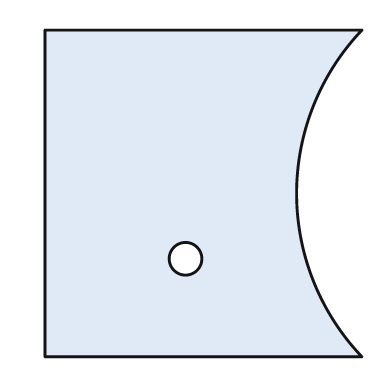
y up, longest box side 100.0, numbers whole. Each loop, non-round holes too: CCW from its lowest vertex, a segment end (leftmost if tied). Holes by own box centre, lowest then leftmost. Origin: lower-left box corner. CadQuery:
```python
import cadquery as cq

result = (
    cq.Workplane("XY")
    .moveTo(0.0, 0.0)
    .lineTo(97.0, 0.0)
    .threePointArc((77.0, 50.0), (97.0, 100.0))
    .lineTo(0.0, 100.0)
    .close()
    .moveTo(43.0, 30.0)
    .circle(5.0)
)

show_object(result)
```